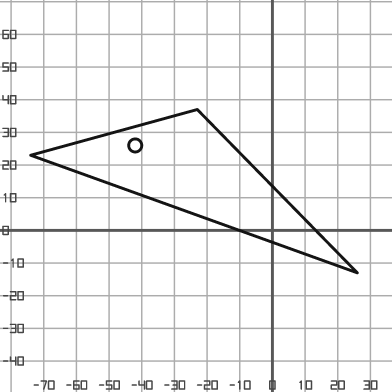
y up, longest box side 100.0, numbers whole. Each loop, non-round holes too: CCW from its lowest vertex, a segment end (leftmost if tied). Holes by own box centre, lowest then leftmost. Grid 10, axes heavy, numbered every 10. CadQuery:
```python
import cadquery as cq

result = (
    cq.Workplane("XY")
    .moveTo(26.0, -13.0)
    .lineTo(-23.0, 37.0)
    .lineTo(-74.0, 23.0)
    .close()
    .moveTo(-42.0, 26.0)
    .circle(2.0)
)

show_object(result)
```